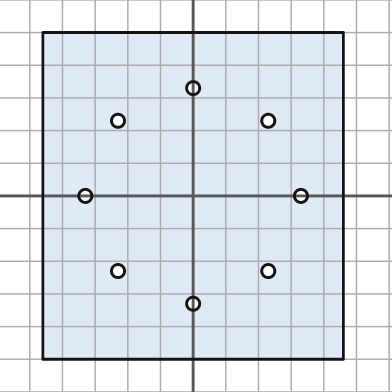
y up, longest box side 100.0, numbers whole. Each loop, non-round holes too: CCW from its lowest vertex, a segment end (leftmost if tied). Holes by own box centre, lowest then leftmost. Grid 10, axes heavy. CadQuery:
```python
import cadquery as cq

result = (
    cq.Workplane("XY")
    .moveTo(-46.0, -50.0)
    .lineTo(46.0, -50.0)
    .lineTo(46.0, 50.0)
    .lineTo(-46.0, 50.0)
    .close()
    .moveTo(0.0, -33.0)
    .circle(2.0)
    .moveTo(-23.0, -23.0)
    .circle(2.0)
    .moveTo(23.0, -23.0)
    .circle(2.0)
    .moveTo(-33.0, 0.0)
    .circle(2.0)
    .moveTo(33.0, 0.0)
    .circle(2.0)
    .moveTo(-23.0, 23.0)
    .circle(2.0)
    .moveTo(23.0, 23.0)
    .circle(2.0)
    .moveTo(0.0, 33.0)
    .circle(2.0)
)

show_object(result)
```